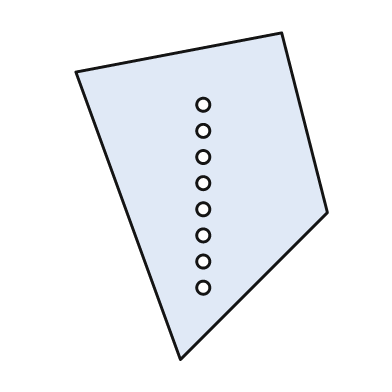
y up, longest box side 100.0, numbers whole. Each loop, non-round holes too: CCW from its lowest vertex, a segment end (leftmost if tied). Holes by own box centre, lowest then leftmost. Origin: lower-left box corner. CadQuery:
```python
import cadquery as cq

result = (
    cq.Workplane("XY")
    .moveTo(32.0, 0.0)
    .lineTo(77.0, 45.0)
    .lineTo(63.0, 100.0)
    .lineTo(0.0, 88.0)
    .close()
    .moveTo(39.0, 22.0)
    .circle(2.0)
    .moveTo(39.0, 30.0)
    .circle(2.0)
    .moveTo(39.0, 38.0)
    .circle(2.0)
    .moveTo(39.0, 46.0)
    .circle(2.0)
    .moveTo(39.0, 54.0)
    .circle(2.0)
    .moveTo(39.0, 62.0)
    .circle(2.0)
    .moveTo(39.0, 70.0)
    .circle(2.0)
    .moveTo(39.0, 78.0)
    .circle(2.0)
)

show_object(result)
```